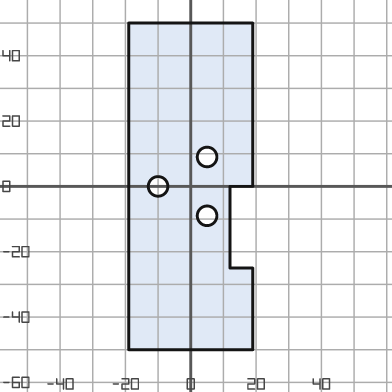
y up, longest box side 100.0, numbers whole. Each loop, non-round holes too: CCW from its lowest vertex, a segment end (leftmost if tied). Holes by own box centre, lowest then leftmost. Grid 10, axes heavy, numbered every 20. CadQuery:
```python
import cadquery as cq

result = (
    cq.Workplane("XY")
    .moveTo(-19.0, -50.0)
    .lineTo(19.0, -50.0)
    .lineTo(19.0, -25.0)
    .lineTo(12.0, -25.0)
    .lineTo(12.0, 0.0)
    .lineTo(19.0, 0.0)
    .lineTo(19.0, 50.0)
    .lineTo(-19.0, 50.0)
    .close()
    .moveTo(5.0, -9.0)
    .circle(3.0)
    .moveTo(-10.0, 0.0)
    .circle(3.0)
    .moveTo(5.0, 9.0)
    .circle(3.0)
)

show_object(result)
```